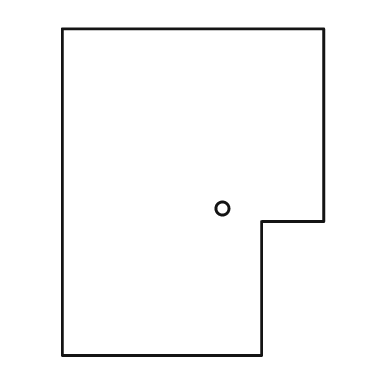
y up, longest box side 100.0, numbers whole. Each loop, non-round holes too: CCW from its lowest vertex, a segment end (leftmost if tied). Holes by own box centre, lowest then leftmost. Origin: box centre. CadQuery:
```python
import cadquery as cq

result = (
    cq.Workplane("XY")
    .moveTo(-40.0, -50.0)
    .lineTo(21.0, -50.0)
    .lineTo(21.0, -9.0)
    .lineTo(40.0, -9.0)
    .lineTo(40.0, 50.0)
    .lineTo(-40.0, 50.0)
    .close()
    .moveTo(9.0, -5.0)
    .circle(2.0)
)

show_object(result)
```